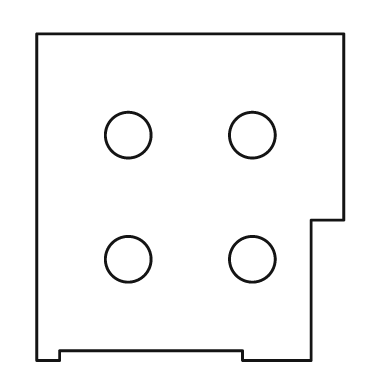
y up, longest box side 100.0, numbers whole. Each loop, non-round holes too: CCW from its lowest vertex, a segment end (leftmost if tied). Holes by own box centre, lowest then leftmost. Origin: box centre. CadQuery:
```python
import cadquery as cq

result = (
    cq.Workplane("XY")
    .moveTo(-47.0, -50.0)
    .lineTo(-40.0, -50.0)
    .lineTo(-40.0, -47.0)
    .lineTo(16.0, -47.0)
    .lineTo(16.0, -50.0)
    .lineTo(37.0, -50.0)
    .lineTo(37.0, -7.0)
    .lineTo(47.0, -7.0)
    .lineTo(47.0, 50.0)
    .lineTo(-47.0, 50.0)
    .close()
    .moveTo(-19.0, -19.0)
    .circle(7.0)
    .moveTo(19.0, -19.0)
    .circle(7.0)
    .moveTo(-19.0, 19.0)
    .circle(7.0)
    .moveTo(19.0, 19.0)
    .circle(7.0)
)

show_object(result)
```